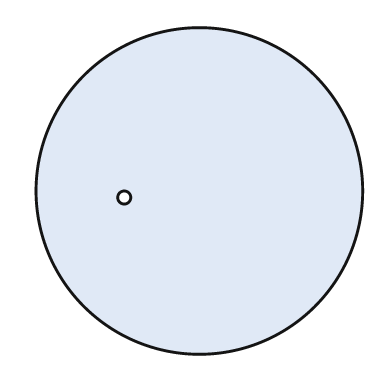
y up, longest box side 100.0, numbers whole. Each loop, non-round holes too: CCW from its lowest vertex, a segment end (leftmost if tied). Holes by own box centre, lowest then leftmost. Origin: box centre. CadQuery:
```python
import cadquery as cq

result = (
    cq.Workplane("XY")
    .moveTo(0.0, 0.0)
    .circle(50.0)
    .moveTo(-23.0, -2.0)
    .circle(2.0)
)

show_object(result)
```